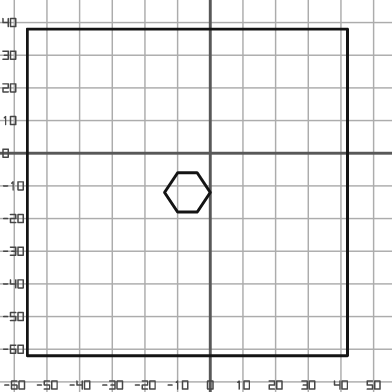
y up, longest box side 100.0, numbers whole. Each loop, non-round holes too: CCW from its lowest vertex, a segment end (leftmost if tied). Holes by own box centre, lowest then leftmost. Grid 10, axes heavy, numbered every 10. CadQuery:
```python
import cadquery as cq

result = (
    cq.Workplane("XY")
    .moveTo(-56.0, -62.0)
    .lineTo(42.0, -62.0)
    .lineTo(42.0, 38.0)
    .lineTo(-56.0, 38.0)
    .close()
    .moveTo(-10.0, -18.0)
    .lineTo(-4.0, -18.0)
    .lineTo(0.0, -12.0)
    .lineTo(-4.0, -6.0)
    .lineTo(-10.0, -6.0)
    .lineTo(-14.0, -12.0)
    .close()
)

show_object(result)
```